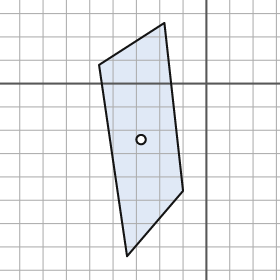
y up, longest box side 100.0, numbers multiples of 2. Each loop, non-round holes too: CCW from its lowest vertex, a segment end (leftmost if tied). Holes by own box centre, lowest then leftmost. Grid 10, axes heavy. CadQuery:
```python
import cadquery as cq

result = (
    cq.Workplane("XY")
    .moveTo(-34.0, -74.0)
    .lineTo(-10.0, -46.0)
    .lineTo(-18.0, 26.0)
    .lineTo(-46.0, 8.0)
    .close()
    .moveTo(-28.0, -24.0)
    .circle(2.0)
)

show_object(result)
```